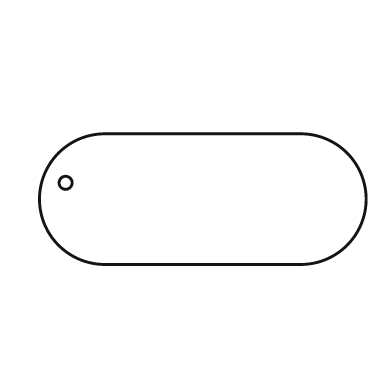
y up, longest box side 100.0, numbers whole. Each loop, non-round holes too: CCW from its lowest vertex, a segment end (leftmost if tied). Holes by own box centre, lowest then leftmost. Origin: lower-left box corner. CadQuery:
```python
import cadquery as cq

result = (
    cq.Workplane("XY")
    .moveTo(20.0, 0.0)
    .lineTo(80.0, 0.0)
    .threePointArc((100.0, 20.0), (80.0, 40.0))
    .lineTo(20.0, 40.0)
    .threePointArc((0.0, 20.0), (20.0, 0.0))
    .close()
    .moveTo(8.0, 25.0)
    .circle(2.0)
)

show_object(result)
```